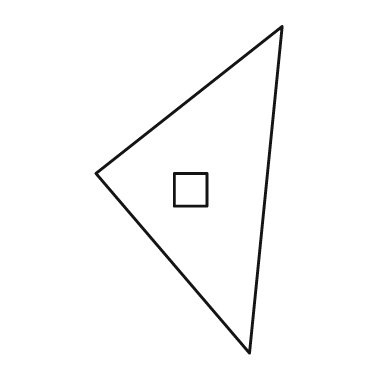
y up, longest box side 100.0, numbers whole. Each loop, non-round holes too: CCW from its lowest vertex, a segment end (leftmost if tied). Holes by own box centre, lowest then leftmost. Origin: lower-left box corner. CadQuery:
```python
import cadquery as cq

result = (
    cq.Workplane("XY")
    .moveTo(47.0, 0.0)
    .lineTo(57.0, 100.0)
    .lineTo(0.0, 55.0)
    .close()
    .moveTo(24.0, 45.0)
    .lineTo(34.0, 45.0)
    .lineTo(34.0, 55.0)
    .lineTo(24.0, 55.0)
    .close()
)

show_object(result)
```